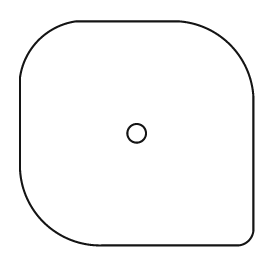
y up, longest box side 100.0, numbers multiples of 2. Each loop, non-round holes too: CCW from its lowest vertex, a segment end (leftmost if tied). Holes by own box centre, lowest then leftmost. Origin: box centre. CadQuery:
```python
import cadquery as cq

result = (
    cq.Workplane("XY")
    .moveTo(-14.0, -48.0)
    .lineTo(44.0, -48.0)
    .threePointArc((48.0, -46.0), (50.0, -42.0))
    .lineTo(50.0, 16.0)
    .threePointArc((40.0, 38.0), (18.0, 48.0))
    .lineTo(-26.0, 48.0)
    .threePointArc((-42.0, 40.0), (-50.0, 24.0))
    .lineTo(-50.0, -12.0)
    .threePointArc((-40.0, -38.0), (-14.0, -48.0))
    .close()
    .moveTo(0.0, 0.0)
    .circle(4.0)
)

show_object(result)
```